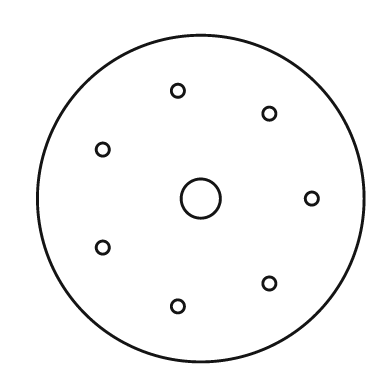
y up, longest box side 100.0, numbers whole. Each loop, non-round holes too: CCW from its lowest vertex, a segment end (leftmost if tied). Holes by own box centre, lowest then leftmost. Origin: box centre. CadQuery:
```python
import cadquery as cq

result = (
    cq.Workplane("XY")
    .moveTo(0.0, 0.0)
    .circle(50.0)
    .moveTo(-7.0, -33.0)
    .circle(2.0)
    .moveTo(21.0, -26.0)
    .circle(2.0)
    .moveTo(-30.0, -15.0)
    .circle(2.0)
    .moveTo(0.0, 0.0)
    .circle(6.0)
    .moveTo(34.0, 0.0)
    .circle(2.0)
    .moveTo(-30.0, 15.0)
    .circle(2.0)
    .moveTo(21.0, 26.0)
    .circle(2.0)
    .moveTo(-7.0, 33.0)
    .circle(2.0)
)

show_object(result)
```